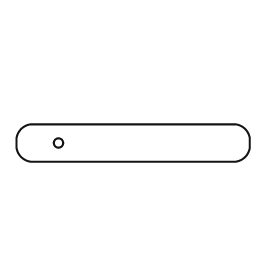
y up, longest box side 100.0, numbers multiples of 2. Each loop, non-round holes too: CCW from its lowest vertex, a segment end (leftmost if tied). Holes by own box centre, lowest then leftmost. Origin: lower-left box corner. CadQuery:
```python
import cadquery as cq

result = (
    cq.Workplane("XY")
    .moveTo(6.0, 0.0)
    .lineTo(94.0, 0.0)
    .threePointArc((98.0, 2.0), (100.0, 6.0))
    .lineTo(100.0, 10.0)
    .threePointArc((98.0, 14.0), (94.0, 16.0))
    .lineTo(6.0, 16.0)
    .threePointArc((2.0, 14.0), (0.0, 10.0))
    .lineTo(0.0, 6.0)
    .threePointArc((2.0, 2.0), (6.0, 0.0))
    .close()
    .moveTo(18.0, 8.0)
    .circle(2.0)
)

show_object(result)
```